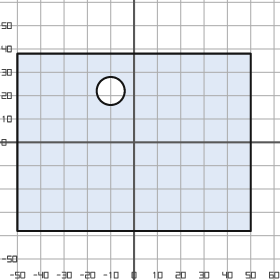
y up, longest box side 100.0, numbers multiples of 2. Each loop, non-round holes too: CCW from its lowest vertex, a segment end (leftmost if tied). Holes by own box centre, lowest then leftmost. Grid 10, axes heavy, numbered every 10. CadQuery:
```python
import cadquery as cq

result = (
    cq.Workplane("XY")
    .moveTo(-50.0, -38.0)
    .lineTo(50.0, -38.0)
    .lineTo(50.0, 38.0)
    .lineTo(-50.0, 38.0)
    .close()
    .moveTo(-10.0, 22.0)
    .circle(6.0)
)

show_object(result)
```